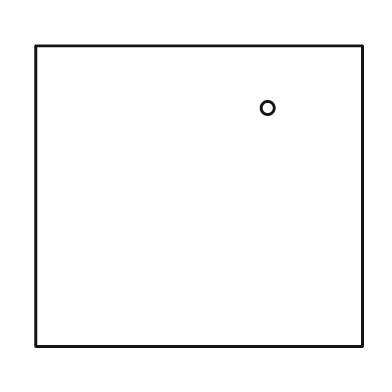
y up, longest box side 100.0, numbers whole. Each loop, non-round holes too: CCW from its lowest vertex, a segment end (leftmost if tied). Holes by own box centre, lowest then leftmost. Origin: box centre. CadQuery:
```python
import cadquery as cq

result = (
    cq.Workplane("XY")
    .moveTo(-50.0, -46.0)
    .lineTo(50.0, -46.0)
    .lineTo(50.0, 46.0)
    .lineTo(-50.0, 46.0)
    .close()
    .moveTo(21.0, 27.0)
    .circle(2.0)
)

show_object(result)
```